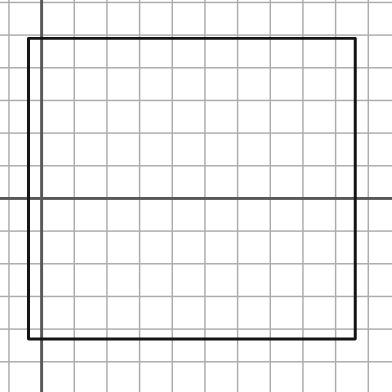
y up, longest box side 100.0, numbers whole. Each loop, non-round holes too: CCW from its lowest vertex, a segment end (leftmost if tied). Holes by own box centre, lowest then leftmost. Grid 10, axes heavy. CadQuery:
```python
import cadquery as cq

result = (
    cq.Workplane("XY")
    .moveTo(-4.0, -43.0)
    .lineTo(96.0, -43.0)
    .lineTo(96.0, 49.0)
    .lineTo(-4.0, 49.0)
    .close()
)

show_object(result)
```